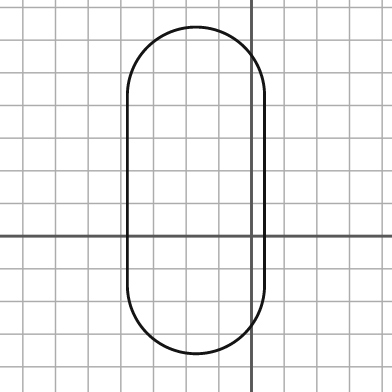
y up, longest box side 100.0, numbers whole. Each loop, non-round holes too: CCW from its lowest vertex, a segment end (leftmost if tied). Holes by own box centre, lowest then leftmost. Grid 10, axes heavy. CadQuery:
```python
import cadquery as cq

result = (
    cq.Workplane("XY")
    .moveTo(-38.0, -15.0)
    .threePointArc((-17.0, -36.0), (4.0, -15.0))
    .lineTo(4.0, 43.0)
    .threePointArc((-17.0, 64.0), (-38.0, 43.0))
    .close()
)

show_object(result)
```